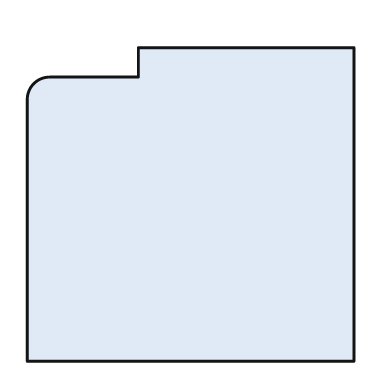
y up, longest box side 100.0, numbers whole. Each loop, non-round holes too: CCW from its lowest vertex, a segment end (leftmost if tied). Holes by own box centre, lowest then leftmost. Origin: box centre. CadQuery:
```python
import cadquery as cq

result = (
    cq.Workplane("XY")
    .moveTo(-50.0, -48.0)
    .lineTo(50.0, -48.0)
    .lineTo(50.0, 48.0)
    .lineTo(-16.0, 48.0)
    .lineTo(-16.0, 39.0)
    .lineTo(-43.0, 39.0)
    .threePointArc((-48.0, 37.0), (-50.0, 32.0))
    .close()
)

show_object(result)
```